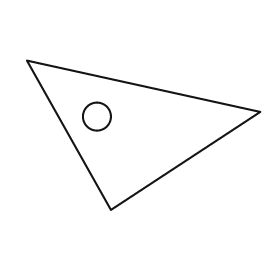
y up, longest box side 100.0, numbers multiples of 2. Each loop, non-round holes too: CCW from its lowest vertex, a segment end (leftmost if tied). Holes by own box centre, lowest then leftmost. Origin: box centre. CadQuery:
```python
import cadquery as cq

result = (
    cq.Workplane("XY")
    .moveTo(-14.0, -32.0)
    .lineTo(50.0, 10.0)
    .lineTo(-50.0, 32.0)
    .close()
    .moveTo(-20.0, 8.0)
    .circle(6.0)
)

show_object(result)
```